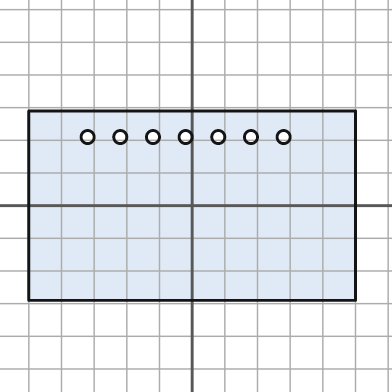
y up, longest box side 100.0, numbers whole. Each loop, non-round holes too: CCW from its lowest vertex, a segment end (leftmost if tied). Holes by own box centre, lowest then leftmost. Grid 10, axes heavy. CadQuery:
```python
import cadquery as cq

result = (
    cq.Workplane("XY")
    .moveTo(-50.0, -29.0)
    .lineTo(50.0, -29.0)
    .lineTo(50.0, 29.0)
    .lineTo(-50.0, 29.0)
    .close()
    .moveTo(-32.0, 21.0)
    .circle(2.0)
    .moveTo(-22.0, 21.0)
    .circle(2.0)
    .moveTo(-12.0, 21.0)
    .circle(2.0)
    .moveTo(-2.0, 21.0)
    .circle(2.0)
    .moveTo(8.0, 21.0)
    .circle(2.0)
    .moveTo(18.0, 21.0)
    .circle(2.0)
    .moveTo(28.0, 21.0)
    .circle(2.0)
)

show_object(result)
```